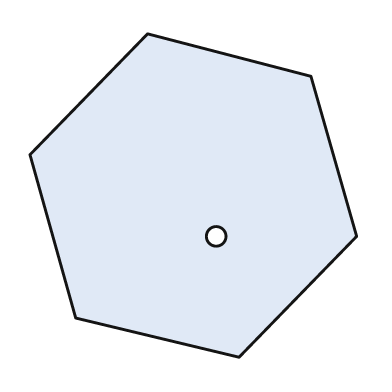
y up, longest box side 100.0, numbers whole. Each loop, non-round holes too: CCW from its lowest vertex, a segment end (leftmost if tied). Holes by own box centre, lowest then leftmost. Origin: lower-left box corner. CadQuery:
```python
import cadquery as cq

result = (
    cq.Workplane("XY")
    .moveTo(64.0, 0.0)
    .lineTo(100.0, 37.0)
    .lineTo(86.0, 86.0)
    .lineTo(36.0, 99.0)
    .lineTo(0.0, 62.0)
    .lineTo(14.0, 12.0)
    .close()
    .moveTo(57.0, 37.0)
    .circle(3.0)
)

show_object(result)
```